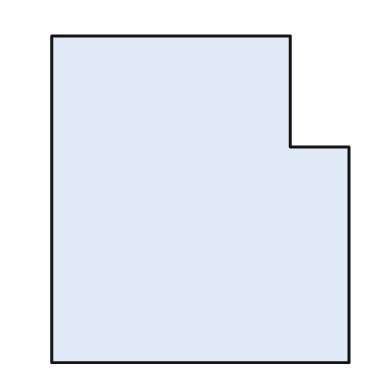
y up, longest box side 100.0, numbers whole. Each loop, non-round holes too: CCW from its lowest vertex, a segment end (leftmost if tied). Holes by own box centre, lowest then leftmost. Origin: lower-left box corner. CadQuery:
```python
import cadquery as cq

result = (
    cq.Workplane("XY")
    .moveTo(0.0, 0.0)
    .lineTo(91.0, 0.0)
    .lineTo(91.0, 66.0)
    .lineTo(73.0, 66.0)
    .lineTo(73.0, 100.0)
    .lineTo(0.0, 100.0)
    .close()
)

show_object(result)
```